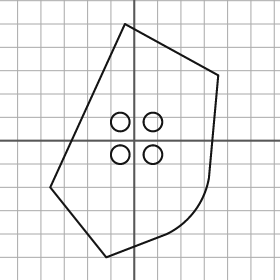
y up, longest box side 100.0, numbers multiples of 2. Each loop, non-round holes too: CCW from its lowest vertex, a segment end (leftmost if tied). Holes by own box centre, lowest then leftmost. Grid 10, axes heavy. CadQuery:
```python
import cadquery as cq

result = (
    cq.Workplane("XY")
    .moveTo(-12.0, -50.0)
    .lineTo(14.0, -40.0)
    .threePointArc((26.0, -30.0), (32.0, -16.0))
    .lineTo(36.0, 28.0)
    .lineTo(-4.0, 50.0)
    .lineTo(-36.0, -20.0)
    .close()
    .moveTo(-6.0, -6.0)
    .circle(4.0)
    .moveTo(8.0, -6.0)
    .circle(4.0)
    .moveTo(-6.0, 8.0)
    .circle(4.0)
    .moveTo(8.0, 8.0)
    .circle(4.0)
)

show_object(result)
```